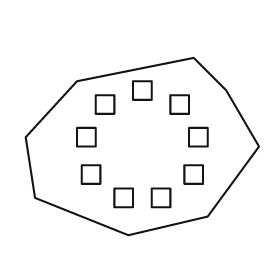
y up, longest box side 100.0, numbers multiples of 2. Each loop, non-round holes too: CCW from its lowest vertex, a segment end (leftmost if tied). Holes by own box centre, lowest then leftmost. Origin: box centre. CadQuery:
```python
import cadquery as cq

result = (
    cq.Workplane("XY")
    .moveTo(-6.0, -38.0)
    .lineTo(28.0, -30.0)
    .lineTo(50.0, 0.0)
    .lineTo(36.0, 24.0)
    .lineTo(22.0, 38.0)
    .lineTo(-28.0, 28.0)
    .lineTo(-50.0, 4.0)
    .lineTo(-46.0, -22.0)
    .close()
    .moveTo(-12.0, -26.0)
    .lineTo(-4.0, -26.0)
    .lineTo(-4.0, -18.0)
    .lineTo(-12.0, -18.0)
    .close()
    .moveTo(4.0, -26.0)
    .lineTo(12.0, -26.0)
    .lineTo(12.0, -18.0)
    .lineTo(4.0, -18.0)
    .close()
    .moveTo(-26.0, -16.0)
    .lineTo(-18.0, -16.0)
    .lineTo(-18.0, -8.0)
    .lineTo(-26.0, -8.0)
    .close()
    .moveTo(18.0, -16.0)
    .lineTo(26.0, -16.0)
    .lineTo(26.0, -8.0)
    .lineTo(18.0, -8.0)
    .close()
    .moveTo(-28.0, 0.0)
    .lineTo(-20.0, 0.0)
    .lineTo(-20.0, 8.0)
    .lineTo(-28.0, 8.0)
    .close()
    .moveTo(20.0, 0.0)
    .lineTo(28.0, 0.0)
    .lineTo(28.0, 8.0)
    .lineTo(20.0, 8.0)
    .close()
    .moveTo(-20.0, 14.0)
    .lineTo(-12.0, 14.0)
    .lineTo(-12.0, 22.0)
    .lineTo(-20.0, 22.0)
    .close()
    .moveTo(12.0, 14.0)
    .lineTo(20.0, 14.0)
    .lineTo(20.0, 22.0)
    .lineTo(12.0, 22.0)
    .close()
    .moveTo(-4.0, 20.0)
    .lineTo(4.0, 20.0)
    .lineTo(4.0, 28.0)
    .lineTo(-4.0, 28.0)
    .close()
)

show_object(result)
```